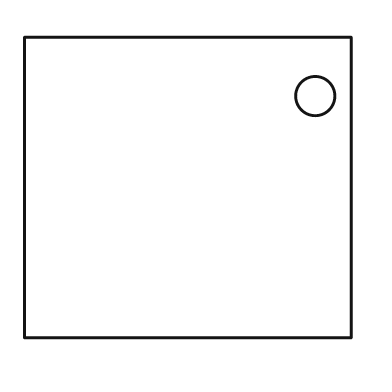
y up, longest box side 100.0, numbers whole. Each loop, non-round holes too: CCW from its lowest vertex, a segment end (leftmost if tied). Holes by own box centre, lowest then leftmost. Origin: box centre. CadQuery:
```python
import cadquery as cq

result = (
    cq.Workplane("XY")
    .moveTo(-50.0, -46.0)
    .lineTo(50.0, -46.0)
    .lineTo(50.0, 46.0)
    .lineTo(-50.0, 46.0)
    .close()
    .moveTo(39.0, 28.0)
    .circle(6.0)
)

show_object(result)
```